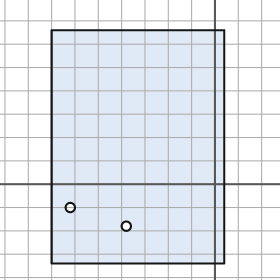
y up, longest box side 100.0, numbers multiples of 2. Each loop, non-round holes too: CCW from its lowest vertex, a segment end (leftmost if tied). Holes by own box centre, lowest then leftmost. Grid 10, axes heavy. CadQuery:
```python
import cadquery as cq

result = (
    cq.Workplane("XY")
    .moveTo(-70.0, -34.0)
    .lineTo(4.0, -34.0)
    .lineTo(4.0, 66.0)
    .lineTo(-70.0, 66.0)
    .close()
    .moveTo(-38.0, -18.0)
    .circle(2.0)
    .moveTo(-62.0, -10.0)
    .circle(2.0)
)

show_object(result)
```